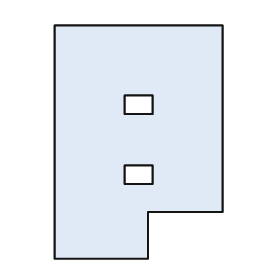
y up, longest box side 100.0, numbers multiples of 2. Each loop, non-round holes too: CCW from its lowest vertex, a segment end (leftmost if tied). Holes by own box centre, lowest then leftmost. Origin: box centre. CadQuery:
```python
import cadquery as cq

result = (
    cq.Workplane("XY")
    .moveTo(-36.0, -50.0)
    .lineTo(4.0, -50.0)
    .lineTo(4.0, -30.0)
    .lineTo(36.0, -30.0)
    .lineTo(36.0, 50.0)
    .lineTo(-36.0, 50.0)
    .close()
    .moveTo(-6.0, -18.0)
    .lineTo(6.0, -18.0)
    .lineTo(6.0, -10.0)
    .lineTo(-6.0, -10.0)
    .close()
    .moveTo(-6.0, 12.0)
    .lineTo(6.0, 12.0)
    .lineTo(6.0, 20.0)
    .lineTo(-6.0, 20.0)
    .close()
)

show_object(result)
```